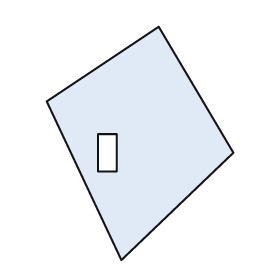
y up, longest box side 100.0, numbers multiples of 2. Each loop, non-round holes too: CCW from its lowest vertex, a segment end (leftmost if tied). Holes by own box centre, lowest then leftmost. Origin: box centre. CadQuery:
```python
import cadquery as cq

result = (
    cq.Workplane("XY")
    .moveTo(-8.0, -50.0)
    .lineTo(40.0, -4.0)
    .lineTo(8.0, 50.0)
    .lineTo(-40.0, 18.0)
    .close()
    .moveTo(-18.0, -12.0)
    .lineTo(-10.0, -12.0)
    .lineTo(-10.0, 4.0)
    .lineTo(-18.0, 4.0)
    .close()
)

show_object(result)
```